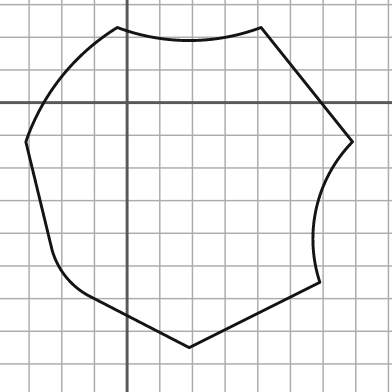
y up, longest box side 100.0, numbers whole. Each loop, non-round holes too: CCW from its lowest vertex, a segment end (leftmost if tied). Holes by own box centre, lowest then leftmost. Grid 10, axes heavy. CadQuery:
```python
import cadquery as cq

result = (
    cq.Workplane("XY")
    .moveTo(19.0, -75.0)
    .lineTo(59.0, -55.0)
    .threePointArc((58.0, -32.0), (69.0, -12.0))
    .lineTo(41.0, 23.0)
    .threePointArc((19.0, 19.0), (-3.0, 23.0))
    .threePointArc((-20.0, 8.0), (-31.0, -12.0))
    .lineTo(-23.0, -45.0)
    .threePointArc((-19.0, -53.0), (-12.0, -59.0))
    .close()
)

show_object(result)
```